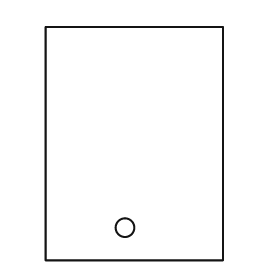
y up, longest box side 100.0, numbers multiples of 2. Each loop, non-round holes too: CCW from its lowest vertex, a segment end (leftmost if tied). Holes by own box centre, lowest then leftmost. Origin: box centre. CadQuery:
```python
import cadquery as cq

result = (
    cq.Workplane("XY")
    .moveTo(-38.0, -50.0)
    .lineTo(38.0, -50.0)
    .lineTo(38.0, 50.0)
    .lineTo(-38.0, 50.0)
    .close()
    .moveTo(-4.0, -36.0)
    .circle(4.0)
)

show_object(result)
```